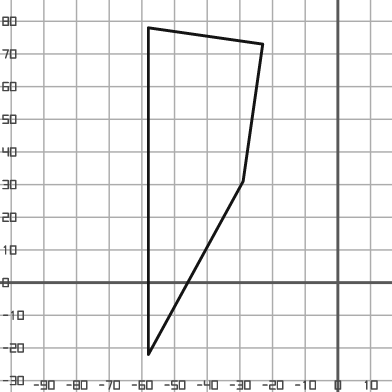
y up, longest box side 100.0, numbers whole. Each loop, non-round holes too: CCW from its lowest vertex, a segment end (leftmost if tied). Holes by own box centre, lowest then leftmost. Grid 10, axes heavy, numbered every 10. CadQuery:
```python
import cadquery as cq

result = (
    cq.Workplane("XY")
    .moveTo(-58.0, -22.0)
    .lineTo(-29.0, 31.0)
    .lineTo(-23.0, 73.0)
    .lineTo(-58.0, 78.0)
    .close()
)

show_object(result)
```